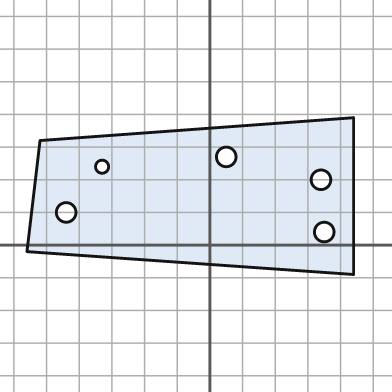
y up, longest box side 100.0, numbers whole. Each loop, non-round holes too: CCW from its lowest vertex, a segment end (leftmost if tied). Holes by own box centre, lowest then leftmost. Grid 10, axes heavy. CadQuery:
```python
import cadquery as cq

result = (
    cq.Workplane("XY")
    .moveTo(44.0, -9.0)
    .lineTo(44.0, 39.0)
    .lineTo(-52.0, 32.0)
    .lineTo(-56.0, -2.0)
    .close()
    .moveTo(35.0, 4.0)
    .circle(3.0)
    .moveTo(-44.0, 10.0)
    .circle(3.0)
    .moveTo(34.0, 20.0)
    .circle(3.0)
    .moveTo(-33.0, 24.0)
    .circle(2.0)
    .moveTo(5.0, 27.0)
    .circle(3.0)
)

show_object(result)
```